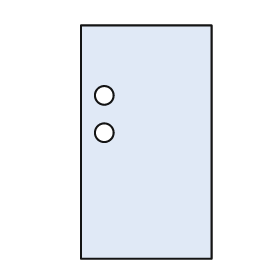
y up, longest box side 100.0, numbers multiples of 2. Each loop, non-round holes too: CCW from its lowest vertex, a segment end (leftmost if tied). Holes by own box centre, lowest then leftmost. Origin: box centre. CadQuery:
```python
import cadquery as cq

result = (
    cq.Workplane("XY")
    .moveTo(-28.0, -50.0)
    .lineTo(28.0, -50.0)
    .lineTo(28.0, 50.0)
    .lineTo(-28.0, 50.0)
    .close()
    .moveTo(-18.0, 4.0)
    .circle(4.0)
    .moveTo(-18.0, 20.0)
    .circle(4.0)
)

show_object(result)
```